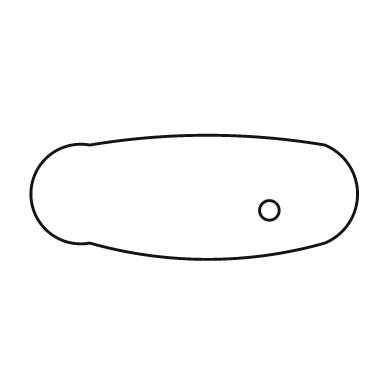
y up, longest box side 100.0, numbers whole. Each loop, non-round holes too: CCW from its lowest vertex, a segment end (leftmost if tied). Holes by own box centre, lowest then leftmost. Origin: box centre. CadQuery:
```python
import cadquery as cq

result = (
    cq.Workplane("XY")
    .moveTo(-32.0, -14.0)
    .threePointArc((4.0, -19.0), (40.0, -14.0))
    .threePointArc((50.0, 1.0), (40.0, 16.0))
    .threePointArc((4.0, 19.0), (-32.0, 16.0))
    .threePointArc((-50.0, 1.0), (-32.0, -14.0))
    .close()
    .moveTo(23.0, -4.0)
    .circle(3.0)
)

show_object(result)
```